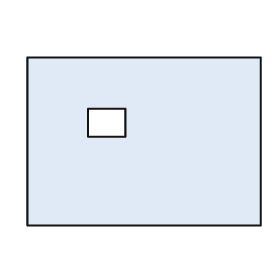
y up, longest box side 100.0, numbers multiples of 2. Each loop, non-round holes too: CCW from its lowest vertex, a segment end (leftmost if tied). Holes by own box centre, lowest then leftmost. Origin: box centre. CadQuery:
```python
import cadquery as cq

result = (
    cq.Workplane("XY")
    .moveTo(-50.0, -36.0)
    .lineTo(50.0, -36.0)
    .lineTo(50.0, 36.0)
    .lineTo(-50.0, 36.0)
    .close()
    .moveTo(-24.0, 2.0)
    .lineTo(-8.0, 2.0)
    .lineTo(-8.0, 14.0)
    .lineTo(-24.0, 14.0)
    .close()
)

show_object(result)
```